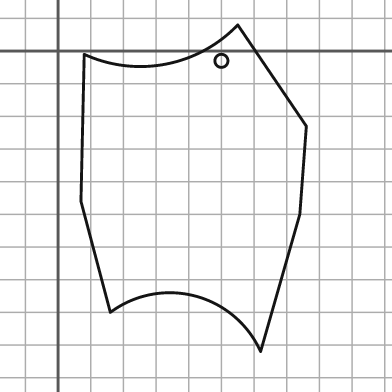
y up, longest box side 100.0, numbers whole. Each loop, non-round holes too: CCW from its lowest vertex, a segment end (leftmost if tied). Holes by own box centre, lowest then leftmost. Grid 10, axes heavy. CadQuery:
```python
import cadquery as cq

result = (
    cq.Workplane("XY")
    .moveTo(62.0, -92.0)
    .lineTo(74.0, -50.0)
    .lineTo(76.0, -23.0)
    .lineTo(55.0, 8.0)
    .threePointArc((33.0, -4.0), (8.0, -1.0))
    .lineTo(7.0, -46.0)
    .lineTo(16.0, -80.0)
    .threePointArc((42.0, -75.0), (62.0, -92.0))
    .close()
    .moveTo(50.0, -3.0)
    .circle(2.0)
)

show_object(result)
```